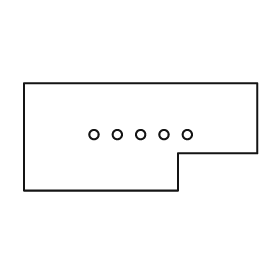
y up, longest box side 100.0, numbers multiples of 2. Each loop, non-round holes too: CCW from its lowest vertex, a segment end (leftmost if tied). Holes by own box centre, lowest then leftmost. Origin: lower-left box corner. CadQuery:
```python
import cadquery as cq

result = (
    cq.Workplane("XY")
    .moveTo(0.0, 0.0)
    .lineTo(66.0, 0.0)
    .lineTo(66.0, 16.0)
    .lineTo(100.0, 16.0)
    .lineTo(100.0, 46.0)
    .lineTo(0.0, 46.0)
    .close()
    .moveTo(30.0, 24.0)
    .circle(2.0)
    .moveTo(40.0, 24.0)
    .circle(2.0)
    .moveTo(50.0, 24.0)
    .circle(2.0)
    .moveTo(60.0, 24.0)
    .circle(2.0)
    .moveTo(70.0, 24.0)
    .circle(2.0)
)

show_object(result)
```